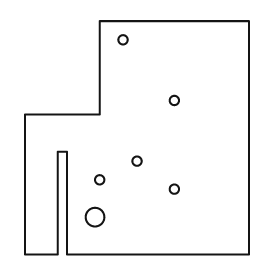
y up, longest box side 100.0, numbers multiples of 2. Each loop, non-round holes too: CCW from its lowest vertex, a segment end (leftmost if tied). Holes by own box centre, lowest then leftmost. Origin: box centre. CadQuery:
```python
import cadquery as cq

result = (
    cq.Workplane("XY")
    .moveTo(-48.0, -50.0)
    .lineTo(-34.0, -50.0)
    .lineTo(-34.0, -6.0)
    .lineTo(-30.0, -6.0)
    .lineTo(-30.0, -50.0)
    .lineTo(48.0, -50.0)
    .lineTo(48.0, 50.0)
    .lineTo(-16.0, 50.0)
    .lineTo(-16.0, 10.0)
    .lineTo(-48.0, 10.0)
    .close()
    .moveTo(-18.0, -34.0)
    .circle(4.0)
    .moveTo(16.0, -22.0)
    .circle(2.0)
    .moveTo(-16.0, -18.0)
    .circle(2.0)
    .moveTo(0.0, -10.0)
    .circle(2.0)
    .moveTo(16.0, 16.0)
    .circle(2.0)
    .moveTo(-6.0, 42.0)
    .circle(2.0)
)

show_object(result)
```